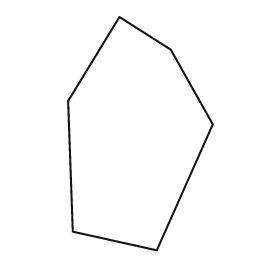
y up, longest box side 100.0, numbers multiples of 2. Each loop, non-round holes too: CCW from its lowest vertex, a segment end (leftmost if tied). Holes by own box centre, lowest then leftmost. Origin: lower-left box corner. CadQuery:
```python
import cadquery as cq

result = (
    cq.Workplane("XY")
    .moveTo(38.0, 0.0)
    .lineTo(62.0, 54.0)
    .lineTo(44.0, 86.0)
    .lineTo(22.0, 100.0)
    .lineTo(0.0, 64.0)
    .lineTo(2.0, 8.0)
    .close()
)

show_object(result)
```